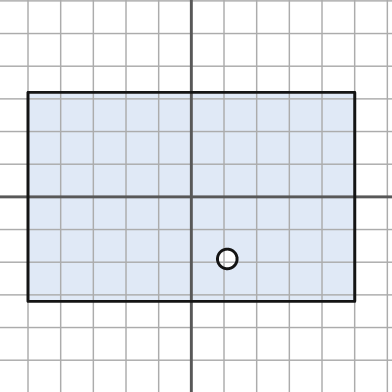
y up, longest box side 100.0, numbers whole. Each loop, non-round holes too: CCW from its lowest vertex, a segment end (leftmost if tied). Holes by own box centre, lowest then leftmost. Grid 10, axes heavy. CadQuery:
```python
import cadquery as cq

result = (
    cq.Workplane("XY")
    .moveTo(-50.0, -32.0)
    .lineTo(50.0, -32.0)
    .lineTo(50.0, 32.0)
    .lineTo(-50.0, 32.0)
    .close()
    .moveTo(11.0, -19.0)
    .circle(3.0)
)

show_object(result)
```